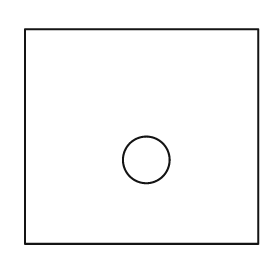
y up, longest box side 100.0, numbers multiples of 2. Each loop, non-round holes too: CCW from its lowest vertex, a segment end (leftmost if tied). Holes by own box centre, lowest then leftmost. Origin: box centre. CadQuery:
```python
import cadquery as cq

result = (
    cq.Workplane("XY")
    .moveTo(-50.0, -46.0)
    .lineTo(50.0, -46.0)
    .lineTo(50.0, 46.0)
    .lineTo(-50.0, 46.0)
    .close()
    .moveTo(2.0, -10.0)
    .circle(10.0)
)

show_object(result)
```